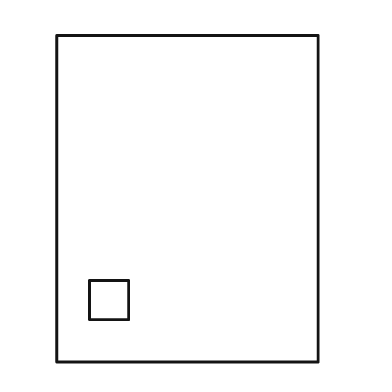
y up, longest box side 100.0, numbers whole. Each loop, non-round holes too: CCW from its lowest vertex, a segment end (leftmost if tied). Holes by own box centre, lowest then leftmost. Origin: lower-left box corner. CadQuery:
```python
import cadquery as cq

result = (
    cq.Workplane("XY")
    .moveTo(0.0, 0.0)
    .lineTo(80.0, 0.0)
    .lineTo(80.0, 100.0)
    .lineTo(0.0, 100.0)
    .close()
    .moveTo(10.0, 13.0)
    .lineTo(22.0, 13.0)
    .lineTo(22.0, 25.0)
    .lineTo(10.0, 25.0)
    .close()
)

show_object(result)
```